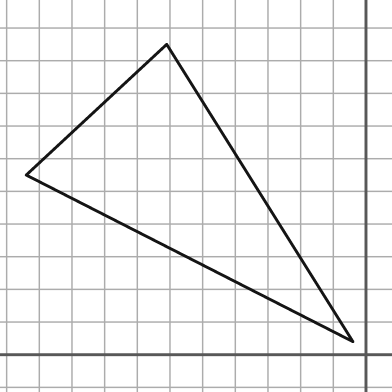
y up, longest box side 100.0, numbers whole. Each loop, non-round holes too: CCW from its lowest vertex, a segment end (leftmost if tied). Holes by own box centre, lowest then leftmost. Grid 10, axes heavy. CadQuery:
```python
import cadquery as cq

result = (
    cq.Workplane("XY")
    .moveTo(-4.0, 4.0)
    .lineTo(-61.0, 95.0)
    .lineTo(-104.0, 55.0)
    .close()
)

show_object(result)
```